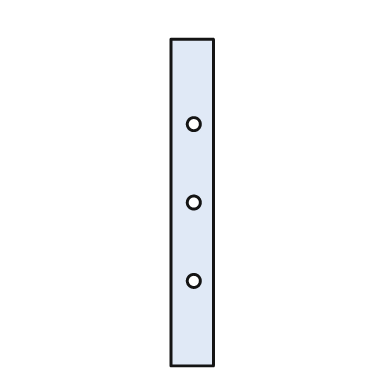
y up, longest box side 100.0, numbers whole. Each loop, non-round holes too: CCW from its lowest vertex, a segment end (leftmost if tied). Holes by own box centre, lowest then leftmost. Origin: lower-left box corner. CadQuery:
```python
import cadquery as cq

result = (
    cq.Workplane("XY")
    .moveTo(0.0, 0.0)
    .lineTo(13.0, 0.0)
    .lineTo(13.0, 100.0)
    .lineTo(0.0, 100.0)
    .close()
    .moveTo(7.0, 26.0)
    .circle(2.0)
    .moveTo(7.0, 50.0)
    .circle(2.0)
    .moveTo(7.0, 74.0)
    .circle(2.0)
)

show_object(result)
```